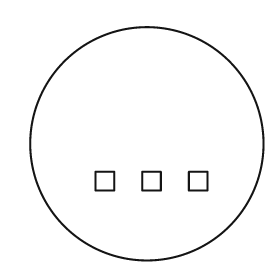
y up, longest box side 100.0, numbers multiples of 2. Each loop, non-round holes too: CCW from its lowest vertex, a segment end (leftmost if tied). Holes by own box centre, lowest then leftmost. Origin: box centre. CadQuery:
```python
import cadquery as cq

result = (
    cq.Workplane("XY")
    .moveTo(0.0, 0.0)
    .circle(50.0)
    .moveTo(-22.0, -20.0)
    .lineTo(-14.0, -20.0)
    .lineTo(-14.0, -12.0)
    .lineTo(-22.0, -12.0)
    .close()
    .moveTo(-2.0, -20.0)
    .lineTo(6.0, -20.0)
    .lineTo(6.0, -12.0)
    .lineTo(-2.0, -12.0)
    .close()
    .moveTo(18.0, -20.0)
    .lineTo(26.0, -20.0)
    .lineTo(26.0, -12.0)
    .lineTo(18.0, -12.0)
    .close()
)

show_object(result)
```